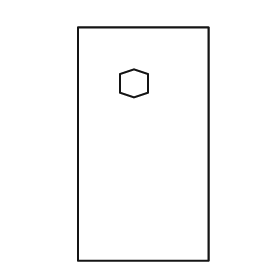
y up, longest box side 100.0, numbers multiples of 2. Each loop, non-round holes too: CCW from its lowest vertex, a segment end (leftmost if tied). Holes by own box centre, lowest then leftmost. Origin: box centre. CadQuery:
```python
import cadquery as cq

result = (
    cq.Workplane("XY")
    .moveTo(-28.0, -50.0)
    .lineTo(28.0, -50.0)
    .lineTo(28.0, 50.0)
    .lineTo(-28.0, 50.0)
    .close()
    .moveTo(-4.0, 20.0)
    .lineTo(2.0, 22.0)
    .lineTo(2.0, 30.0)
    .lineTo(-4.0, 32.0)
    .lineTo(-10.0, 30.0)
    .lineTo(-10.0, 22.0)
    .close()
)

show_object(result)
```